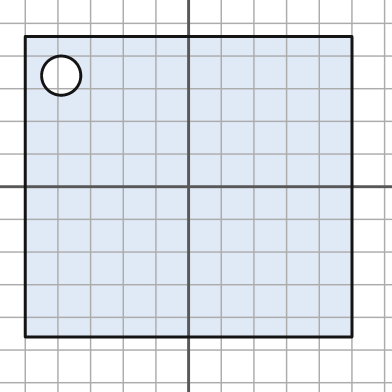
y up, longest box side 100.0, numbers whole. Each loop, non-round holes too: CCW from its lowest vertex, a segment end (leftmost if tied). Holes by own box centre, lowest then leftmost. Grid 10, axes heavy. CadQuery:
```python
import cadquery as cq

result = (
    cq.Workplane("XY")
    .moveTo(-50.0, -46.0)
    .lineTo(50.0, -46.0)
    .lineTo(50.0, 46.0)
    .lineTo(-50.0, 46.0)
    .close()
    .moveTo(-39.0, 34.0)
    .circle(6.0)
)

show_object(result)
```